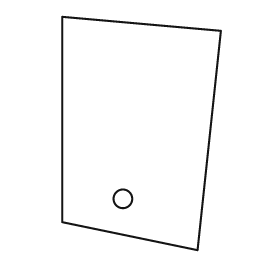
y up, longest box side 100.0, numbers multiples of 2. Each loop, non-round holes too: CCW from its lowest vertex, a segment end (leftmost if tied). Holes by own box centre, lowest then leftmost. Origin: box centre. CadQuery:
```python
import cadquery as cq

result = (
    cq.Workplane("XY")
    .moveTo(24.0, -50.0)
    .lineTo(34.0, 44.0)
    .lineTo(-34.0, 50.0)
    .lineTo(-34.0, -38.0)
    .close()
    .moveTo(-8.0, -28.0)
    .circle(4.0)
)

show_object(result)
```